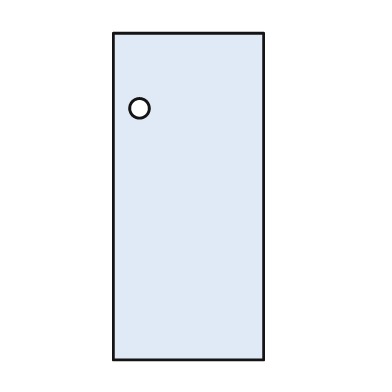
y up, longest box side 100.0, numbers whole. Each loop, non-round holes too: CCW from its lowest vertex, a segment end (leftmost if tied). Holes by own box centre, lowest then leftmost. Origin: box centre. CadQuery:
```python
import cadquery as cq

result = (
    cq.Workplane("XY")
    .moveTo(-23.0, -50.0)
    .lineTo(23.0, -50.0)
    .lineTo(23.0, 50.0)
    .lineTo(-23.0, 50.0)
    .close()
    .moveTo(-15.0, 27.0)
    .circle(3.0)
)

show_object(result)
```